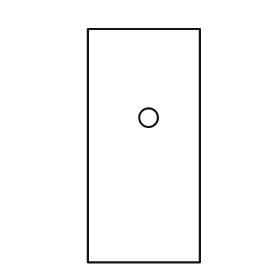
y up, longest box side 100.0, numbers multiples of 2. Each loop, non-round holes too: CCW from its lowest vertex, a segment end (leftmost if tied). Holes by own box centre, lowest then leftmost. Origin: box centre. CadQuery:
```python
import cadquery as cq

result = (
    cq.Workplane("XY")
    .moveTo(-24.0, -50.0)
    .lineTo(24.0, -50.0)
    .lineTo(24.0, 50.0)
    .lineTo(-24.0, 50.0)
    .close()
    .moveTo(2.0, 12.0)
    .circle(4.0)
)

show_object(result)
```